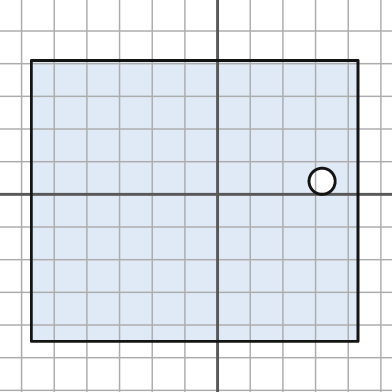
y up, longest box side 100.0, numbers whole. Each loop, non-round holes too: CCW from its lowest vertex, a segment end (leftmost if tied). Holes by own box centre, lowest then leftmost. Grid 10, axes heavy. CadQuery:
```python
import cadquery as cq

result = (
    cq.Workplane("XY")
    .moveTo(-57.0, -45.0)
    .lineTo(43.0, -45.0)
    .lineTo(43.0, 41.0)
    .lineTo(-57.0, 41.0)
    .close()
    .moveTo(32.0, 4.0)
    .circle(4.0)
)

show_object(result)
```